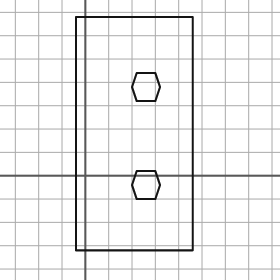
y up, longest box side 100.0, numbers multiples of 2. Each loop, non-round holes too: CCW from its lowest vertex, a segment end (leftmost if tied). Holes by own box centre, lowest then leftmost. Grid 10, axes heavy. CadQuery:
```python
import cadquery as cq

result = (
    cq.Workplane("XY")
    .moveTo(-4.0, -32.0)
    .lineTo(46.0, -32.0)
    .lineTo(46.0, 68.0)
    .lineTo(-4.0, 68.0)
    .close()
    .moveTo(22.0, -10.0)
    .lineTo(30.0, -10.0)
    .lineTo(32.0, -4.0)
    .lineTo(30.0, 2.0)
    .lineTo(22.0, 2.0)
    .lineTo(20.0, -4.0)
    .close()
    .moveTo(22.0, 32.0)
    .lineTo(30.0, 32.0)
    .lineTo(32.0, 38.0)
    .lineTo(30.0, 44.0)
    .lineTo(22.0, 44.0)
    .lineTo(20.0, 38.0)
    .close()
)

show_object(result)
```